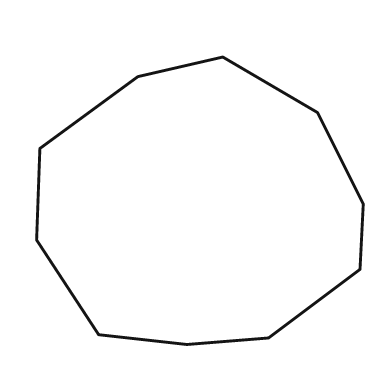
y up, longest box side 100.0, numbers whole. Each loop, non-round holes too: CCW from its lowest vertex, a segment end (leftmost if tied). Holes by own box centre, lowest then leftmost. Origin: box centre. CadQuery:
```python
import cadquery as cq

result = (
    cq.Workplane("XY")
    .moveTo(-4.0, -44.0)
    .lineTo(21.0, -42.0)
    .lineTo(49.0, -21.0)
    .lineTo(50.0, -1.0)
    .lineTo(36.0, 27.0)
    .lineTo(7.0, 44.0)
    .lineTo(-19.0, 38.0)
    .lineTo(-49.0, 16.0)
    .lineTo(-50.0, -12.0)
    .lineTo(-31.0, -41.0)
    .close()
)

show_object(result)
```